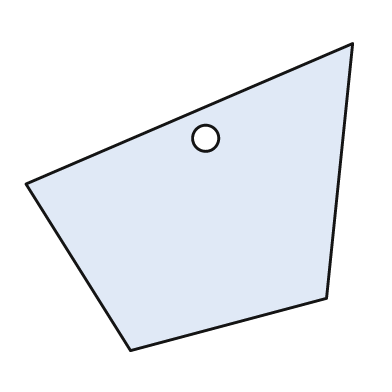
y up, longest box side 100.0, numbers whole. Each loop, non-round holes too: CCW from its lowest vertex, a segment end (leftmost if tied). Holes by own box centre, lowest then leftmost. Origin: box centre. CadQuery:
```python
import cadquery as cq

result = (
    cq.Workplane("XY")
    .moveTo(-18.0, -47.0)
    .lineTo(42.0, -31.0)
    .lineTo(50.0, 47.0)
    .lineTo(-50.0, 4.0)
    .close()
    .moveTo(5.0, 18.0)
    .circle(4.0)
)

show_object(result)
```